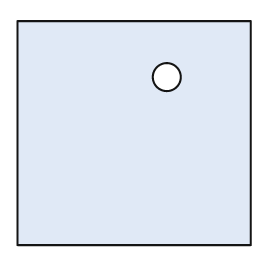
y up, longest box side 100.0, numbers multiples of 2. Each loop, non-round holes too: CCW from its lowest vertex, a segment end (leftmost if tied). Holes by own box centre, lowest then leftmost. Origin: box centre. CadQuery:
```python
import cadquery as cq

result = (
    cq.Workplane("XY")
    .moveTo(-50.0, -48.0)
    .lineTo(50.0, -48.0)
    .lineTo(50.0, 48.0)
    .lineTo(-50.0, 48.0)
    .close()
    .moveTo(14.0, 24.0)
    .circle(6.0)
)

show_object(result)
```